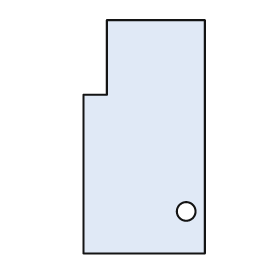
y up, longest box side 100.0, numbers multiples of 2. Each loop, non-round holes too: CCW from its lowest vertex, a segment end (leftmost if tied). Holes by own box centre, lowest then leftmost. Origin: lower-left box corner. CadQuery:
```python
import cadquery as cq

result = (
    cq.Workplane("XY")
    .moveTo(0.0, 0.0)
    .lineTo(52.0, 0.0)
    .lineTo(52.0, 100.0)
    .lineTo(10.0, 100.0)
    .lineTo(10.0, 68.0)
    .lineTo(0.0, 68.0)
    .close()
    .moveTo(44.0, 18.0)
    .circle(4.0)
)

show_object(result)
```